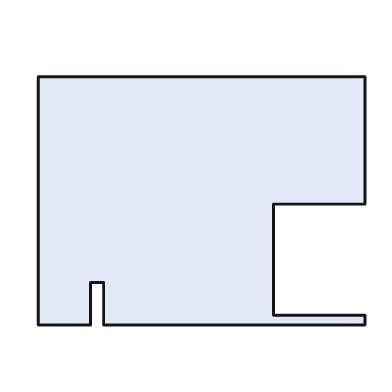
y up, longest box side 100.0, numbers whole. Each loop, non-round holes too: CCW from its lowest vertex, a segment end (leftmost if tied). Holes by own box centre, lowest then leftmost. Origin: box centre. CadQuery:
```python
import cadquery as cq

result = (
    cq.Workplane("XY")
    .moveTo(-50.0, -38.0)
    .lineTo(-34.0, -38.0)
    .lineTo(-34.0, -25.0)
    .lineTo(-30.0, -25.0)
    .lineTo(-30.0, -38.0)
    .lineTo(50.0, -38.0)
    .lineTo(50.0, -35.0)
    .lineTo(22.0, -35.0)
    .lineTo(22.0, -1.0)
    .lineTo(50.0, -1.0)
    .lineTo(50.0, 38.0)
    .lineTo(-50.0, 38.0)
    .close()
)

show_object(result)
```